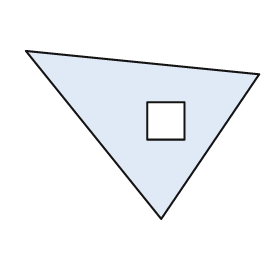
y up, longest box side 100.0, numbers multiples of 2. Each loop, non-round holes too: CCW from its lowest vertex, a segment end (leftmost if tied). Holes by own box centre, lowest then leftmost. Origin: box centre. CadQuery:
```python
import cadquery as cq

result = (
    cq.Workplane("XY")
    .moveTo(8.0, -36.0)
    .lineTo(50.0, 26.0)
    .lineTo(-50.0, 36.0)
    .close()
    .moveTo(2.0, -2.0)
    .lineTo(18.0, -2.0)
    .lineTo(18.0, 14.0)
    .lineTo(2.0, 14.0)
    .close()
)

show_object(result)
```